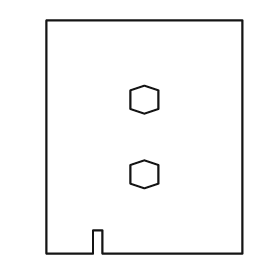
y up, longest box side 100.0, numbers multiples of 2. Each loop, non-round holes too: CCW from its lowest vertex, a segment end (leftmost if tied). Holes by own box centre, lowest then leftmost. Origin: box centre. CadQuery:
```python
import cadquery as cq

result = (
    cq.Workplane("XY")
    .moveTo(-42.0, -50.0)
    .lineTo(-22.0, -50.0)
    .lineTo(-22.0, -40.0)
    .lineTo(-18.0, -40.0)
    .lineTo(-18.0, -50.0)
    .lineTo(42.0, -50.0)
    .lineTo(42.0, 50.0)
    .lineTo(-42.0, 50.0)
    .close()
    .moveTo(0.0, -22.0)
    .lineTo(6.0, -20.0)
    .lineTo(6.0, -12.0)
    .lineTo(0.0, -10.0)
    .lineTo(-6.0, -12.0)
    .lineTo(-6.0, -20.0)
    .close()
    .moveTo(0.0, 10.0)
    .lineTo(6.0, 12.0)
    .lineTo(6.0, 20.0)
    .lineTo(0.0, 22.0)
    .lineTo(-6.0, 20.0)
    .lineTo(-6.0, 12.0)
    .close()
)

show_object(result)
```